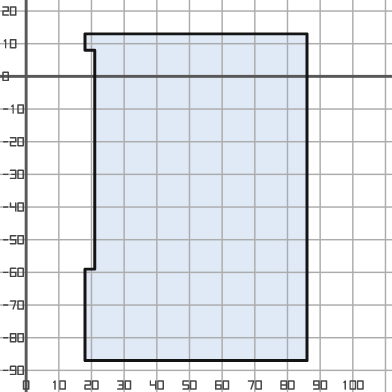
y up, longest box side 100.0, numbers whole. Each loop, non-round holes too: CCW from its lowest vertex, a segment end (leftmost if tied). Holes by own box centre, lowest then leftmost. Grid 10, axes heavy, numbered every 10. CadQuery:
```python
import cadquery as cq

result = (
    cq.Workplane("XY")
    .moveTo(18.0, -87.0)
    .lineTo(86.0, -87.0)
    .lineTo(86.0, 13.0)
    .lineTo(18.0, 13.0)
    .lineTo(18.0, 8.0)
    .lineTo(21.0, 8.0)
    .lineTo(21.0, -59.0)
    .lineTo(18.0, -59.0)
    .close()
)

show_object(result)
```